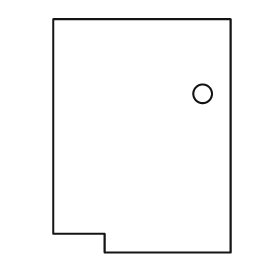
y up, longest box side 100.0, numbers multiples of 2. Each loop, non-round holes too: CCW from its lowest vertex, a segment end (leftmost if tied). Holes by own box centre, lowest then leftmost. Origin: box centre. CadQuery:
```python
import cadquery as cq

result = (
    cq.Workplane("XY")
    .moveTo(-16.0, -50.0)
    .lineTo(38.0, -50.0)
    .lineTo(38.0, 50.0)
    .lineTo(-38.0, 50.0)
    .lineTo(-38.0, -42.0)
    .lineTo(-16.0, -42.0)
    .close()
    .moveTo(26.0, 18.0)
    .circle(4.0)
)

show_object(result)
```